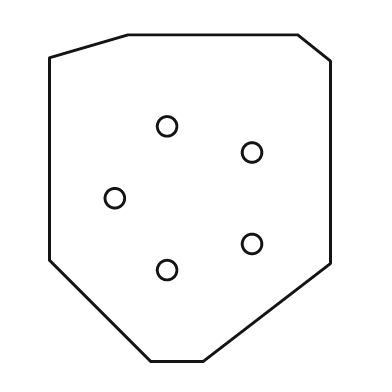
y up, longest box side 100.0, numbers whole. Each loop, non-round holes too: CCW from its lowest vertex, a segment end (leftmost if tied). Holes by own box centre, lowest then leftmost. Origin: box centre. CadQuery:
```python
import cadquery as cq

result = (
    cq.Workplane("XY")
    .moveTo(-12.0, -50.0)
    .lineTo(4.0, -50.0)
    .lineTo(43.0, -20.0)
    .lineTo(43.0, 42.0)
    .lineTo(33.0, 50.0)
    .lineTo(-19.0, 50.0)
    .lineTo(-43.0, 43.0)
    .lineTo(-43.0, -19.0)
    .close()
    .moveTo(-7.0, -22.0)
    .circle(3.0)
    .moveTo(19.0, -14.0)
    .circle(3.0)
    .moveTo(-23.0, 0.0)
    .circle(3.0)
    .moveTo(19.0, 14.0)
    .circle(3.0)
    .moveTo(-7.0, 22.0)
    .circle(3.0)
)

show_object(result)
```